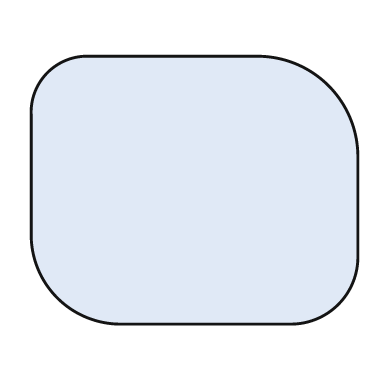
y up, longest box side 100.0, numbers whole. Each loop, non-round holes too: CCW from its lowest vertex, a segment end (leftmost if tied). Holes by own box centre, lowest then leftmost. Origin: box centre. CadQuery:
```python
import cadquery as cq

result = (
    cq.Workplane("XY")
    .moveTo(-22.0, -41.0)
    .lineTo(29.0, -41.0)
    .threePointArc((44.0, -35.0), (50.0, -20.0))
    .lineTo(50.0, 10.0)
    .threePointArc((41.0, 32.0), (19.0, 41.0))
    .lineTo(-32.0, 41.0)
    .threePointArc((-45.0, 36.0), (-50.0, 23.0))
    .lineTo(-50.0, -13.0)
    .threePointArc((-42.0, -33.0), (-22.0, -41.0))
    .close()
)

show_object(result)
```